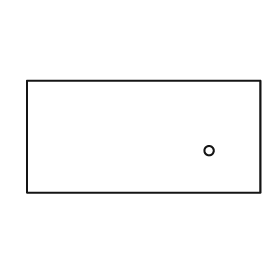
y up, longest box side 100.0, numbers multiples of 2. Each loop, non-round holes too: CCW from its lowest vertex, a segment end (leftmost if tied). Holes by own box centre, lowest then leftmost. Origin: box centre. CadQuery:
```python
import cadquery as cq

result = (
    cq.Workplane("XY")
    .moveTo(-50.0, -24.0)
    .lineTo(50.0, -24.0)
    .lineTo(50.0, 24.0)
    .lineTo(-50.0, 24.0)
    .close()
    .moveTo(28.0, -6.0)
    .circle(2.0)
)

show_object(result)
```